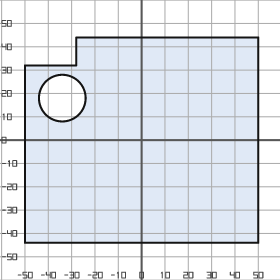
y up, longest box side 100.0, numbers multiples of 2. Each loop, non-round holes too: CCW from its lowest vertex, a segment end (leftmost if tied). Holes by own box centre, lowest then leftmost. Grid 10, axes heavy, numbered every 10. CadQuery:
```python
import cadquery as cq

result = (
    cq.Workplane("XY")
    .moveTo(-50.0, -44.0)
    .lineTo(50.0, -44.0)
    .lineTo(50.0, 44.0)
    .lineTo(-28.0, 44.0)
    .lineTo(-28.0, 32.0)
    .lineTo(-50.0, 32.0)
    .close()
    .moveTo(-34.0, 18.0)
    .circle(10.0)
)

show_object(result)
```